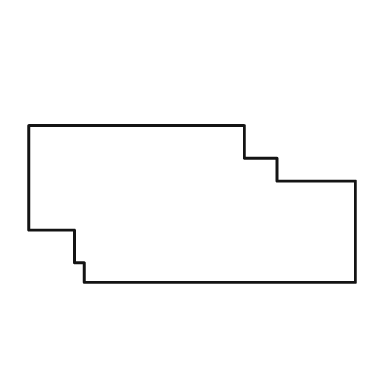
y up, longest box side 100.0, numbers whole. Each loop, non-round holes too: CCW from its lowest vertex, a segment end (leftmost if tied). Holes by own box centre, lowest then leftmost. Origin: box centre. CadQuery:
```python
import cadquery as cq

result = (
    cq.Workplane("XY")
    .moveTo(-33.0, -24.0)
    .lineTo(50.0, -24.0)
    .lineTo(50.0, 7.0)
    .lineTo(26.0, 7.0)
    .lineTo(26.0, 14.0)
    .lineTo(16.0, 14.0)
    .lineTo(16.0, 24.0)
    .lineTo(-50.0, 24.0)
    .lineTo(-50.0, -8.0)
    .lineTo(-36.0, -8.0)
    .lineTo(-36.0, -18.0)
    .lineTo(-33.0, -18.0)
    .close()
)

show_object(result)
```